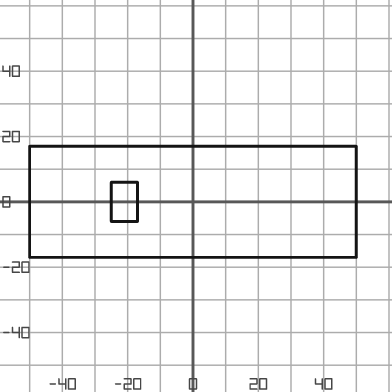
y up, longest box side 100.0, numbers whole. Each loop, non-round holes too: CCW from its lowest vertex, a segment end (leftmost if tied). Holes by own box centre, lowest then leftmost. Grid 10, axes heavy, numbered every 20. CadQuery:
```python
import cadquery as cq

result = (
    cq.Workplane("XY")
    .moveTo(-50.0, -17.0)
    .lineTo(50.0, -17.0)
    .lineTo(50.0, 17.0)
    .lineTo(-50.0, 17.0)
    .close()
    .moveTo(-25.0, -6.0)
    .lineTo(-17.0, -6.0)
    .lineTo(-17.0, 6.0)
    .lineTo(-25.0, 6.0)
    .close()
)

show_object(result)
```